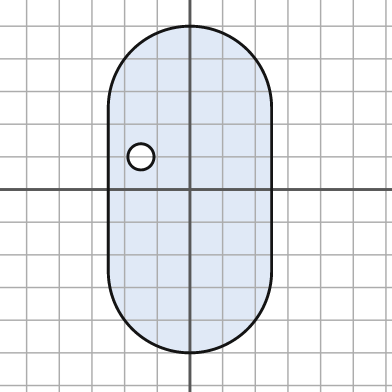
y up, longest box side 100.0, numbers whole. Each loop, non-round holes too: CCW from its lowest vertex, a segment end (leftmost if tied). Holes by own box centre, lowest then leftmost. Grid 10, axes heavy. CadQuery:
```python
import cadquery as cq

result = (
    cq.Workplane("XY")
    .moveTo(-25.0, -25.0)
    .threePointArc((0.0, -50.0), (25.0, -25.0))
    .lineTo(25.0, 25.0)
    .threePointArc((0.0, 50.0), (-25.0, 25.0))
    .close()
    .moveTo(-15.0, 10.0)
    .circle(4.0)
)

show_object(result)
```